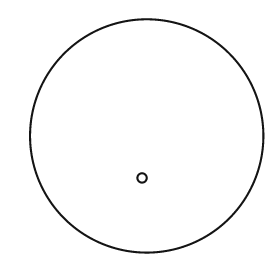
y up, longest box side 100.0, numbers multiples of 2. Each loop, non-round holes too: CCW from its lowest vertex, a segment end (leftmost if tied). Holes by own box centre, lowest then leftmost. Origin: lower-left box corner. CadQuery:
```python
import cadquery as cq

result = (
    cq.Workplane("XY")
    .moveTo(50.0, 50.0)
    .circle(50.0)
    .moveTo(48.0, 32.0)
    .circle(2.0)
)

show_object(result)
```